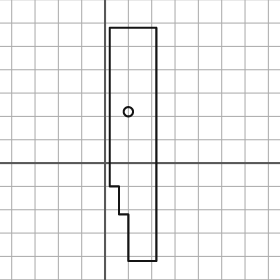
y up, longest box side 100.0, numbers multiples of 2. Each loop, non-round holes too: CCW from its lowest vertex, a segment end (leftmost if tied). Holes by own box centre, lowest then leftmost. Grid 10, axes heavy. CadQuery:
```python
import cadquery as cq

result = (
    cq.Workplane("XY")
    .moveTo(10.0, -42.0)
    .lineTo(22.0, -42.0)
    .lineTo(22.0, 58.0)
    .lineTo(2.0, 58.0)
    .lineTo(2.0, -10.0)
    .lineTo(6.0, -10.0)
    .lineTo(6.0, -22.0)
    .lineTo(10.0, -22.0)
    .close()
    .moveTo(10.0, 22.0)
    .circle(2.0)
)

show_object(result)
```